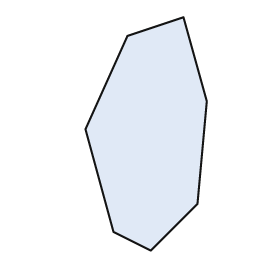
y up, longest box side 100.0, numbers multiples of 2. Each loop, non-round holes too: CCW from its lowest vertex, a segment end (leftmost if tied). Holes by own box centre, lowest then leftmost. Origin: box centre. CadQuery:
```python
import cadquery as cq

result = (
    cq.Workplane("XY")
    .moveTo(2.0, -50.0)
    .lineTo(22.0, -30.0)
    .lineTo(26.0, 14.0)
    .lineTo(16.0, 50.0)
    .lineTo(-8.0, 42.0)
    .lineTo(-26.0, 2.0)
    .lineTo(-14.0, -42.0)
    .close()
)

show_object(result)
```